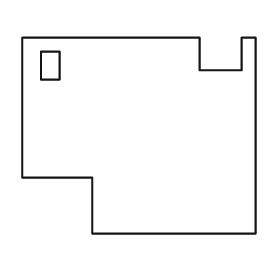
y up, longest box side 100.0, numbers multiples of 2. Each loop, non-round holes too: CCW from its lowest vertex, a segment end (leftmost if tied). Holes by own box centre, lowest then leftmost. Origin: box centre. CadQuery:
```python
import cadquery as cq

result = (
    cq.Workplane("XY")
    .moveTo(-20.0, -42.0)
    .lineTo(50.0, -42.0)
    .lineTo(50.0, 42.0)
    .lineTo(44.0, 42.0)
    .lineTo(44.0, 28.0)
    .lineTo(26.0, 28.0)
    .lineTo(26.0, 42.0)
    .lineTo(-50.0, 42.0)
    .lineTo(-50.0, -18.0)
    .lineTo(-20.0, -18.0)
    .close()
    .moveTo(-42.0, 24.0)
    .lineTo(-34.0, 24.0)
    .lineTo(-34.0, 36.0)
    .lineTo(-42.0, 36.0)
    .close()
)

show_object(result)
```